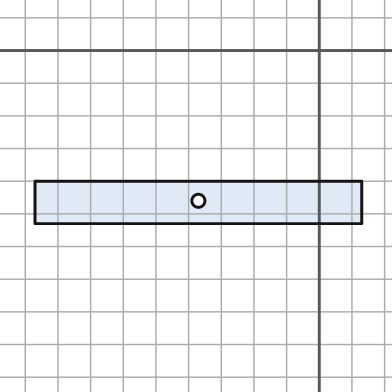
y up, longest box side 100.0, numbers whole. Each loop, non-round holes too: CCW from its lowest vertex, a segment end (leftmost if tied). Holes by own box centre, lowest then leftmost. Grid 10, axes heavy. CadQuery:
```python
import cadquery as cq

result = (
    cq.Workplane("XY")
    .moveTo(-87.0, -53.0)
    .lineTo(13.0, -53.0)
    .lineTo(13.0, -40.0)
    .lineTo(-87.0, -40.0)
    .close()
    .moveTo(-37.0, -46.0)
    .circle(2.0)
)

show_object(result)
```